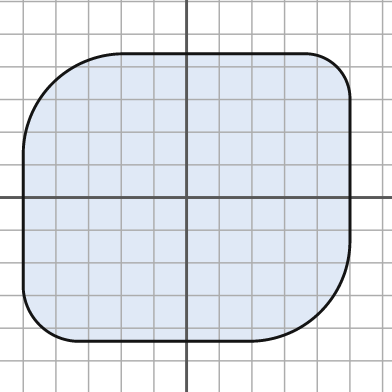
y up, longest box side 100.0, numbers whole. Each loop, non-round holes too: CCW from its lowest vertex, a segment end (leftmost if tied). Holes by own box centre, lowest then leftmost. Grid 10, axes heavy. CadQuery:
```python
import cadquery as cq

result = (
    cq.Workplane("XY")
    .moveTo(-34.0, -44.0)
    .lineTo(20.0, -44.0)
    .threePointArc((41.0, -35.0), (50.0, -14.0))
    .lineTo(50.0, 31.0)
    .threePointArc((46.0, 40.0), (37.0, 44.0))
    .lineTo(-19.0, 44.0)
    .threePointArc((-41.0, 35.0), (-50.0, 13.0))
    .lineTo(-50.0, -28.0)
    .threePointArc((-45.0, -39.0), (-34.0, -44.0))
    .close()
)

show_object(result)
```